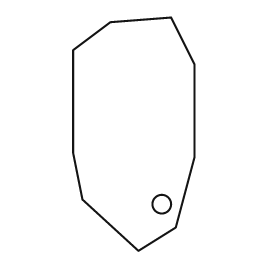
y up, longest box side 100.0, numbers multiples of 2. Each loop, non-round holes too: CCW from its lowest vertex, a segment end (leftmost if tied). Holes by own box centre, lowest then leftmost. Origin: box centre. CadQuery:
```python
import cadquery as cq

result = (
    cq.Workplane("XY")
    .moveTo(2.0, -50.0)
    .lineTo(18.0, -40.0)
    .lineTo(26.0, -10.0)
    .lineTo(26.0, 30.0)
    .lineTo(16.0, 50.0)
    .lineTo(-10.0, 48.0)
    .lineTo(-26.0, 36.0)
    .lineTo(-26.0, -8.0)
    .lineTo(-22.0, -28.0)
    .close()
    .moveTo(12.0, -30.0)
    .circle(4.0)
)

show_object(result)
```